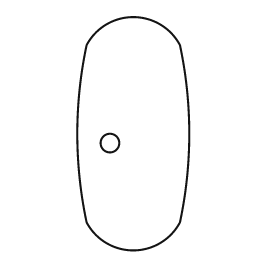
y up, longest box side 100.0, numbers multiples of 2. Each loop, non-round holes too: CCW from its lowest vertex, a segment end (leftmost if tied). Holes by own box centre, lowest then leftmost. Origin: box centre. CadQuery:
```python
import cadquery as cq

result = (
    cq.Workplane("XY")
    .moveTo(-20.0, -38.0)
    .threePointArc((0.0, -50.0), (20.0, -38.0))
    .threePointArc((24.0, 0.0), (20.0, 38.0))
    .threePointArc((0.0, 50.0), (-20.0, 38.0))
    .threePointArc((-24.0, 0.0), (-20.0, -38.0))
    .close()
    .moveTo(-10.0, -4.0)
    .circle(4.0)
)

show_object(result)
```